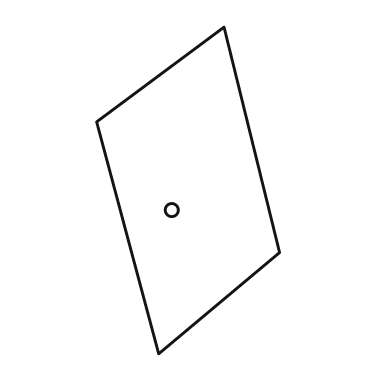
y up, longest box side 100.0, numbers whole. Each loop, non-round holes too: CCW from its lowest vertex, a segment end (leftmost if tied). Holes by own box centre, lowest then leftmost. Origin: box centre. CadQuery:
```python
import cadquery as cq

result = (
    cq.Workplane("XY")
    .moveTo(-9.0, -50.0)
    .lineTo(28.0, -19.0)
    .lineTo(11.0, 50.0)
    .lineTo(-28.0, 21.0)
    .close()
    .moveTo(-5.0, -6.0)
    .circle(2.0)
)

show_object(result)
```